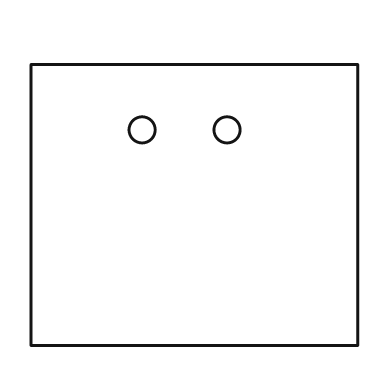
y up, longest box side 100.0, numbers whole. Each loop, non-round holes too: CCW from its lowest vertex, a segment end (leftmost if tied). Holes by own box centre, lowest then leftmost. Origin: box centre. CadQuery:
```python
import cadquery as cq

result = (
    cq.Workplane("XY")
    .moveTo(-50.0, -43.0)
    .lineTo(50.0, -43.0)
    .lineTo(50.0, 43.0)
    .lineTo(-50.0, 43.0)
    .close()
    .moveTo(-16.0, 23.0)
    .circle(4.0)
    .moveTo(10.0, 23.0)
    .circle(4.0)
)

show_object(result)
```